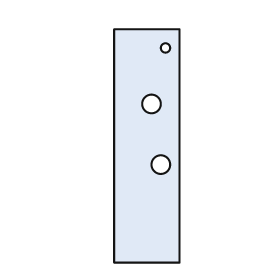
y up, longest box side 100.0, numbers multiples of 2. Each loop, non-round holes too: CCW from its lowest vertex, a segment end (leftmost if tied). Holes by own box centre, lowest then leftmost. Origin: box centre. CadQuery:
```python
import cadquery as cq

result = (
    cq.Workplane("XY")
    .moveTo(-14.0, -50.0)
    .lineTo(14.0, -50.0)
    .lineTo(14.0, 50.0)
    .lineTo(-14.0, 50.0)
    .close()
    .moveTo(6.0, -8.0)
    .circle(4.0)
    .moveTo(2.0, 18.0)
    .circle(4.0)
    .moveTo(8.0, 42.0)
    .circle(2.0)
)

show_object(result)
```